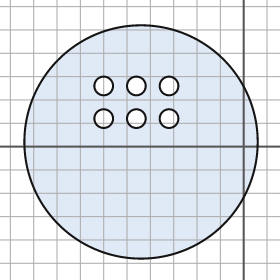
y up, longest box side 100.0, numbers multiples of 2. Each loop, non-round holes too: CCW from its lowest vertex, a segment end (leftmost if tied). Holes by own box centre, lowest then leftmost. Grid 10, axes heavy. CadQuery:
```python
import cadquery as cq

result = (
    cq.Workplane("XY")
    .moveTo(-44.0, 2.0)
    .circle(50.0)
    .moveTo(-60.0, 12.0)
    .circle(4.0)
    .moveTo(-46.0, 12.0)
    .circle(4.0)
    .moveTo(-32.0, 12.0)
    .circle(4.0)
    .moveTo(-60.0, 26.0)
    .circle(4.0)
    .moveTo(-46.0, 26.0)
    .circle(4.0)
    .moveTo(-32.0, 26.0)
    .circle(4.0)
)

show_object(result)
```